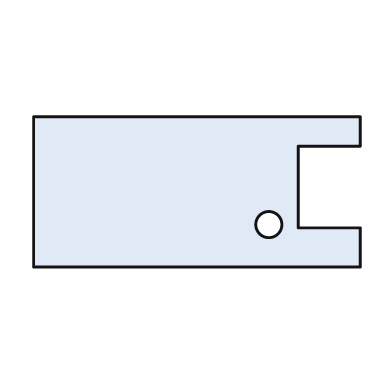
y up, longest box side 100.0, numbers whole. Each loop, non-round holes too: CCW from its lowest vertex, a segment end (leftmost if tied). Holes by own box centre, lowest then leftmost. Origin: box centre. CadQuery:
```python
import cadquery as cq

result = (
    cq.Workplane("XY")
    .moveTo(-50.0, -23.0)
    .lineTo(50.0, -23.0)
    .lineTo(50.0, -11.0)
    .lineTo(31.0, -11.0)
    .lineTo(31.0, 14.0)
    .lineTo(50.0, 14.0)
    .lineTo(50.0, 23.0)
    .lineTo(-50.0, 23.0)
    .close()
    .moveTo(22.0, -10.0)
    .circle(4.0)
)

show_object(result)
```